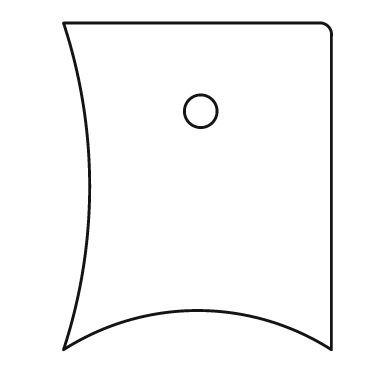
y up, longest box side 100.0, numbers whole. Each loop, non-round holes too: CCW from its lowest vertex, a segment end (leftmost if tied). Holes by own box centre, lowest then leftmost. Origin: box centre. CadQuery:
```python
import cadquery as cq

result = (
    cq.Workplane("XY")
    .moveTo(-41.0, -50.0)
    .threePointArc((0.0, -38.0), (41.0, -50.0))
    .lineTo(41.0, 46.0)
    .threePointArc((40.0, 49.0), (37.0, 50.0))
    .lineTo(-41.0, 50.0)
    .threePointArc((-33.0, 0.0), (-41.0, -50.0))
    .close()
    .moveTo(1.0, 23.0)
    .circle(5.0)
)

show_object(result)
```